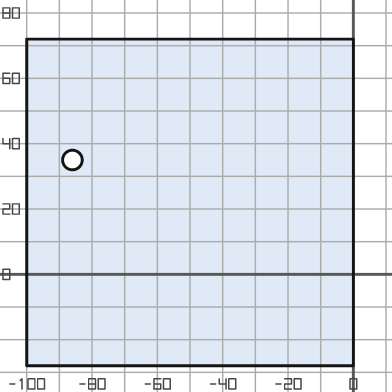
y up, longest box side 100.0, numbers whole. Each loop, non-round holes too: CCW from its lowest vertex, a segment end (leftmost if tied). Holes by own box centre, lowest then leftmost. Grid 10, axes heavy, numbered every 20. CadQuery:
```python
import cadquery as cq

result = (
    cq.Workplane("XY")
    .moveTo(-100.0, -28.0)
    .lineTo(0.0, -28.0)
    .lineTo(0.0, 72.0)
    .lineTo(-100.0, 72.0)
    .close()
    .moveTo(-86.0, 35.0)
    .circle(3.0)
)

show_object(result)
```